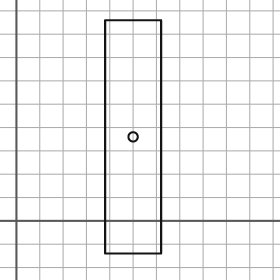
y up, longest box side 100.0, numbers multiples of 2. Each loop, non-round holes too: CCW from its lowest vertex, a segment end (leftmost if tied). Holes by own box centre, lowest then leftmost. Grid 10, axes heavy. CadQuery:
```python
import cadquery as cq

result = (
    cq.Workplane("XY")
    .moveTo(38.0, -14.0)
    .lineTo(62.0, -14.0)
    .lineTo(62.0, 86.0)
    .lineTo(38.0, 86.0)
    .close()
    .moveTo(50.0, 36.0)
    .circle(2.0)
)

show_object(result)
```